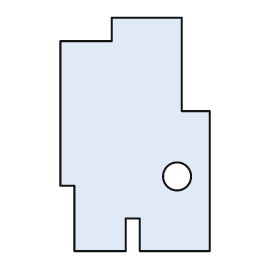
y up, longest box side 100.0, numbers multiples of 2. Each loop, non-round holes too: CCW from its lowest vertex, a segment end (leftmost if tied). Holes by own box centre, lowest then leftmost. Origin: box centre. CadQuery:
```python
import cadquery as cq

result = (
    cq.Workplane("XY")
    .moveTo(-26.0, -50.0)
    .lineTo(-4.0, -50.0)
    .lineTo(-4.0, -36.0)
    .lineTo(2.0, -36.0)
    .lineTo(2.0, -50.0)
    .lineTo(32.0, -50.0)
    .lineTo(32.0, 10.0)
    .lineTo(20.0, 10.0)
    .lineTo(20.0, 50.0)
    .lineTo(-10.0, 50.0)
    .lineTo(-10.0, 40.0)
    .lineTo(-32.0, 40.0)
    .lineTo(-32.0, -22.0)
    .lineTo(-26.0, -22.0)
    .close()
    .moveTo(18.0, -18.0)
    .circle(6.0)
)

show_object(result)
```